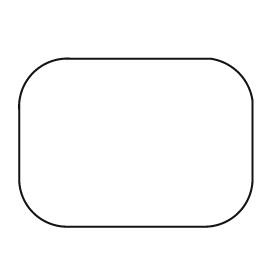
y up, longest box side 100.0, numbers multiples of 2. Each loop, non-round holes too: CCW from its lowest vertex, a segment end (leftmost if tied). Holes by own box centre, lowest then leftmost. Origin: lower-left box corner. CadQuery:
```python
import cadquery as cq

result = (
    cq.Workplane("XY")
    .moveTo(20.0, 0.0)
    .lineTo(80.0, 0.0)
    .threePointArc((94.0, 6.0), (100.0, 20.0))
    .lineTo(100.0, 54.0)
    .threePointArc((94.0, 66.0), (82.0, 72.0))
    .lineTo(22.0, 72.0)
    .threePointArc((6.0, 66.0), (0.0, 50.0))
    .lineTo(0.0, 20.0)
    .threePointArc((6.0, 6.0), (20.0, 0.0))
    .close()
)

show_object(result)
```